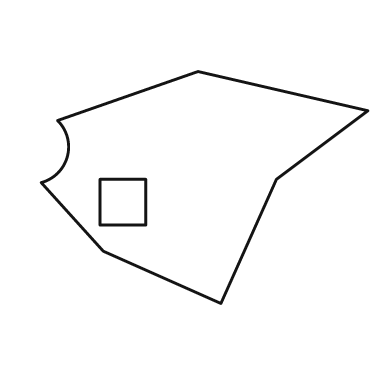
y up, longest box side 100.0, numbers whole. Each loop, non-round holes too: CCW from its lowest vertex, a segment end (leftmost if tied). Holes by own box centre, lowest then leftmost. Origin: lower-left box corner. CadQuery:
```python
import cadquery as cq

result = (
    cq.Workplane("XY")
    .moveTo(55.0, 0.0)
    .lineTo(72.0, 38.0)
    .lineTo(100.0, 59.0)
    .lineTo(48.0, 71.0)
    .lineTo(5.0, 56.0)
    .threePointArc((8.0, 45.0), (0.0, 37.0))
    .lineTo(19.0, 16.0)
    .close()
    .moveTo(18.0, 24.0)
    .lineTo(32.0, 24.0)
    .lineTo(32.0, 38.0)
    .lineTo(18.0, 38.0)
    .close()
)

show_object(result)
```